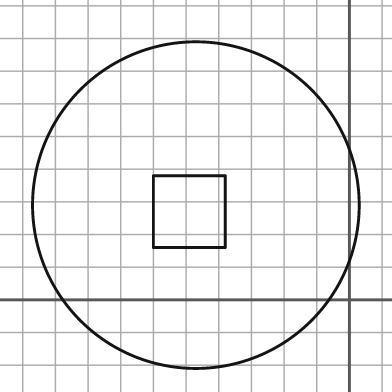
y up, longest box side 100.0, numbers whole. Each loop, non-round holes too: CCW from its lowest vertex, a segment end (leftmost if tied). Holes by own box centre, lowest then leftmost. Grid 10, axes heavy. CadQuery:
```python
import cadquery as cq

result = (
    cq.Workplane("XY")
    .moveTo(-47.0, 29.0)
    .circle(50.0)
    .moveTo(-60.0, 16.0)
    .lineTo(-38.0, 16.0)
    .lineTo(-38.0, 38.0)
    .lineTo(-60.0, 38.0)
    .close()
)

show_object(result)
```